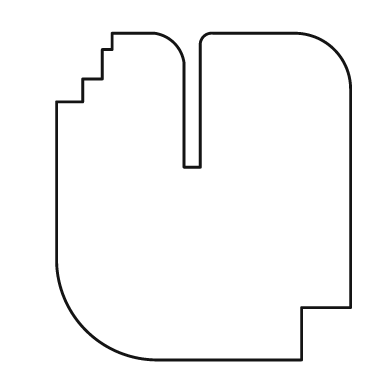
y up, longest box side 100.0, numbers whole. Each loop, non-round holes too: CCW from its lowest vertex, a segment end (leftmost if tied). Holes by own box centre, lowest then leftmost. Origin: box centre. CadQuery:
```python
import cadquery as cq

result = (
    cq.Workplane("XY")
    .moveTo(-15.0, -50.0)
    .lineTo(30.0, -50.0)
    .lineTo(30.0, -34.0)
    .lineTo(45.0, -34.0)
    .lineTo(45.0, 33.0)
    .threePointArc((40.0, 45.0), (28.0, 50.0))
    .lineTo(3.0, 50.0)
    .threePointArc((0.0, 49.0), (-1.0, 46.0))
    .lineTo(-1.0, 9.0)
    .lineTo(-6.0, 9.0)
    .lineTo(-6.0, 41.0)
    .threePointArc((-9.0, 47.0), (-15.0, 50.0))
    .lineTo(-28.0, 50.0)
    .lineTo(-28.0, 45.0)
    .lineTo(-31.0, 45.0)
    .lineTo(-31.0, 36.0)
    .lineTo(-37.0, 36.0)
    .lineTo(-37.0, 29.0)
    .lineTo(-45.0, 29.0)
    .lineTo(-45.0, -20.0)
    .threePointArc((-36.0, -41.0), (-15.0, -50.0))
    .close()
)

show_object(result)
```